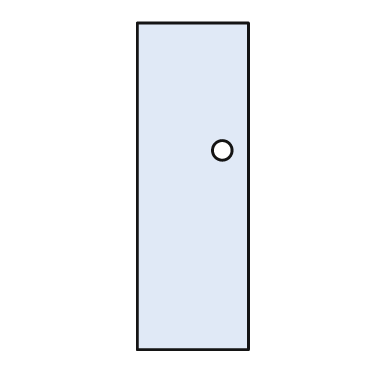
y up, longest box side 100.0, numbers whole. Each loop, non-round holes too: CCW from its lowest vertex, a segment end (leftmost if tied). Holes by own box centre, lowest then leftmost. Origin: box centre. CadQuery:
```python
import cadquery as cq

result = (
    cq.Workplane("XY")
    .moveTo(-17.0, -50.0)
    .lineTo(17.0, -50.0)
    .lineTo(17.0, 50.0)
    .lineTo(-17.0, 50.0)
    .close()
    .moveTo(9.0, 11.0)
    .circle(3.0)
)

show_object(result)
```